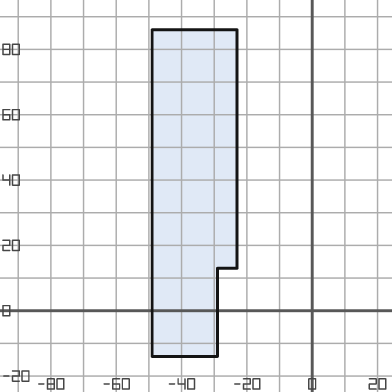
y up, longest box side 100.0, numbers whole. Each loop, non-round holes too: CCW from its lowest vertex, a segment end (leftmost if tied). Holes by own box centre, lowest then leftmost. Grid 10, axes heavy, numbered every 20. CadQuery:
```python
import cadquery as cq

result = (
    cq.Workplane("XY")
    .moveTo(-49.0, -14.0)
    .lineTo(-29.0, -14.0)
    .lineTo(-29.0, 13.0)
    .lineTo(-23.0, 13.0)
    .lineTo(-23.0, 86.0)
    .lineTo(-49.0, 86.0)
    .close()
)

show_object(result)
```